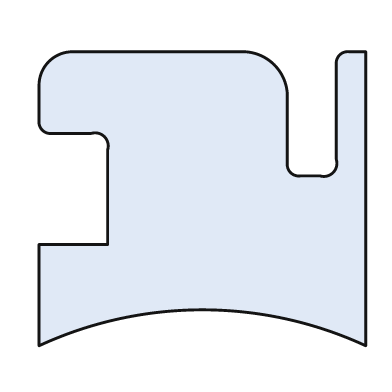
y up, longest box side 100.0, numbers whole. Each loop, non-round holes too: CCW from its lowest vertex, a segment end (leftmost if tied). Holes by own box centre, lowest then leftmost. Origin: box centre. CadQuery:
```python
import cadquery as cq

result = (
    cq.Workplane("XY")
    .moveTo(-50.0, -45.0)
    .threePointArc((0.0, -34.0), (50.0, -45.0))
    .lineTo(50.0, 45.0)
    .lineTo(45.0, 45.0)
    .threePointArc((42.0, 44.0), (41.0, 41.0))
    .lineTo(41.0, 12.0)
    .threePointArc((40.0, 8.0), (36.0, 7.0))
    .lineTo(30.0, 7.0)
    .threePointArc((27.0, 8.0), (26.0, 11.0))
    .lineTo(26.0, 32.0)
    .threePointArc((22.0, 41.0), (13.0, 45.0))
    .lineTo(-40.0, 45.0)
    .threePointArc((-47.0, 42.0), (-50.0, 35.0))
    .lineTo(-50.0, 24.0)
    .threePointArc((-49.0, 21.0), (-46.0, 20.0))
    .lineTo(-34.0, 20.0)
    .threePointArc((-30.0, 19.0), (-29.0, 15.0))
    .lineTo(-29.0, -14.0)
    .lineTo(-50.0, -14.0)
    .close()
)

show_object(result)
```